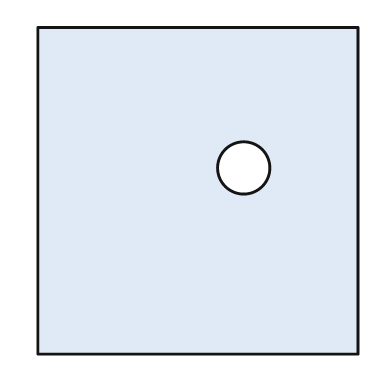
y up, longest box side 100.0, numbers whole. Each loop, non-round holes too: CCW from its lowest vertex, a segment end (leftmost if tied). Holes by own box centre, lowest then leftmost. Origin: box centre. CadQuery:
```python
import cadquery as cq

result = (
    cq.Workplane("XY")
    .moveTo(-49.0, -50.0)
    .lineTo(49.0, -50.0)
    .lineTo(49.0, 50.0)
    .lineTo(-49.0, 50.0)
    .close()
    .moveTo(14.0, 7.0)
    .circle(8.0)
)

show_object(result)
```